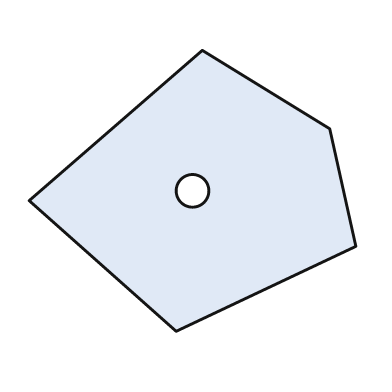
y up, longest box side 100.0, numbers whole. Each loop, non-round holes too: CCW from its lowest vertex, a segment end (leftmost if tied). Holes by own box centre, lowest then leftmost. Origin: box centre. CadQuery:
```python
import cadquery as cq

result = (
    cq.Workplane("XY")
    .moveTo(-5.0, -43.0)
    .lineTo(50.0, -17.0)
    .lineTo(42.0, 19.0)
    .lineTo(3.0, 43.0)
    .lineTo(-50.0, -3.0)
    .close()
    .moveTo(0.0, 0.0)
    .circle(5.0)
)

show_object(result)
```